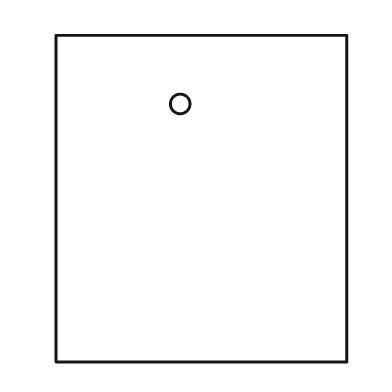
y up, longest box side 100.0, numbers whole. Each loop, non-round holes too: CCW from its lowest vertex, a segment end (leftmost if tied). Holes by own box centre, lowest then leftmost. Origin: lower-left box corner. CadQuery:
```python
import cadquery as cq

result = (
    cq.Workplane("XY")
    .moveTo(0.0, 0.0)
    .lineTo(89.0, 0.0)
    .lineTo(89.0, 100.0)
    .lineTo(0.0, 100.0)
    .close()
    .moveTo(38.0, 79.0)
    .circle(3.0)
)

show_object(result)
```